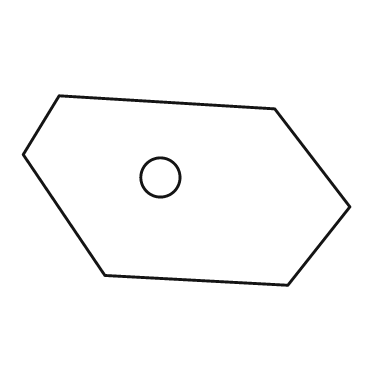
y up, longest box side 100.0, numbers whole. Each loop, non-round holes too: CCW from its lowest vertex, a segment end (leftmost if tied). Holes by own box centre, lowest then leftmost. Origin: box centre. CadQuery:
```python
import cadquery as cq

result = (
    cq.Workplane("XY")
    .moveTo(31.0, -29.0)
    .lineTo(50.0, -5.0)
    .lineTo(27.0, 25.0)
    .lineTo(-39.0, 29.0)
    .lineTo(-50.0, 11.0)
    .lineTo(-25.0, -26.0)
    .close()
    .moveTo(-8.0, 4.0)
    .circle(6.0)
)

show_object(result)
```